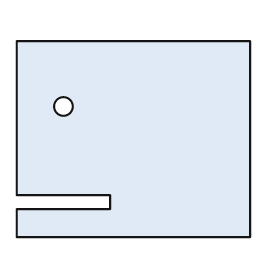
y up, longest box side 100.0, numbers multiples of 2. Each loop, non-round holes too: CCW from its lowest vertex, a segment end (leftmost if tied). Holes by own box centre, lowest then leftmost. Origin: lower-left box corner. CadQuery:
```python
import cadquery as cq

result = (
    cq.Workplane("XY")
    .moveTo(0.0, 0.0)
    .lineTo(100.0, 0.0)
    .lineTo(100.0, 84.0)
    .lineTo(0.0, 84.0)
    .lineTo(0.0, 18.0)
    .lineTo(40.0, 18.0)
    .lineTo(40.0, 12.0)
    .lineTo(0.0, 12.0)
    .close()
    .moveTo(20.0, 56.0)
    .circle(4.0)
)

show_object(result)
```